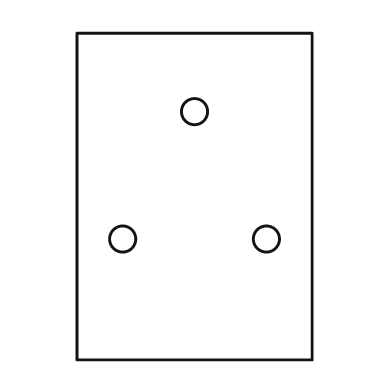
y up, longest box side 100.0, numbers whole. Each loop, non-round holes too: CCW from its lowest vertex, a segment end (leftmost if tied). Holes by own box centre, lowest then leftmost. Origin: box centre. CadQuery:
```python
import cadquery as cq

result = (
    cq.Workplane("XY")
    .moveTo(-36.0, -50.0)
    .lineTo(36.0, -50.0)
    .lineTo(36.0, 50.0)
    .lineTo(-36.0, 50.0)
    .close()
    .moveTo(-22.0, -13.0)
    .circle(4.0)
    .moveTo(22.0, -13.0)
    .circle(4.0)
    .moveTo(0.0, 26.0)
    .circle(4.0)
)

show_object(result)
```